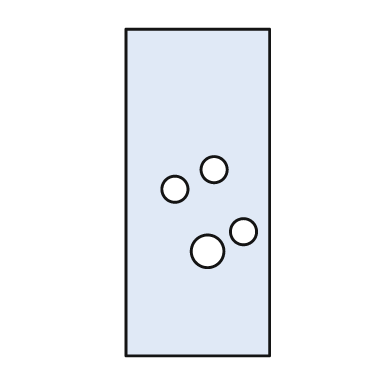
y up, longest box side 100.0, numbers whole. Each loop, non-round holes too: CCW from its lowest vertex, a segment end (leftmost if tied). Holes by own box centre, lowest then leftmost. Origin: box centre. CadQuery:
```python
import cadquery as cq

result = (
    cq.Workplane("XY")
    .moveTo(-22.0, -50.0)
    .lineTo(22.0, -50.0)
    .lineTo(22.0, 50.0)
    .lineTo(-22.0, 50.0)
    .close()
    .moveTo(3.0, -18.0)
    .circle(5.0)
    .moveTo(14.0, -12.0)
    .circle(4.0)
    .moveTo(-7.0, 1.0)
    .circle(4.0)
    .moveTo(5.0, 7.0)
    .circle(4.0)
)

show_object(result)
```